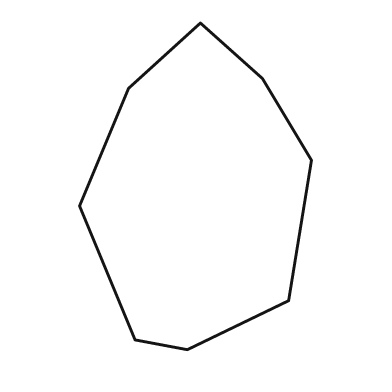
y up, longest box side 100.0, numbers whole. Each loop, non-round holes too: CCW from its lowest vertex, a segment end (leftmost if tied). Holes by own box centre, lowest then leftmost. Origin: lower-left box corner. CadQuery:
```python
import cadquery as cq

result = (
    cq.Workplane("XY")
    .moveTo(33.0, 0.0)
    .lineTo(64.0, 15.0)
    .lineTo(71.0, 58.0)
    .lineTo(56.0, 83.0)
    .lineTo(37.0, 100.0)
    .lineTo(15.0, 80.0)
    .lineTo(0.0, 44.0)
    .lineTo(17.0, 3.0)
    .close()
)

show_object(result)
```